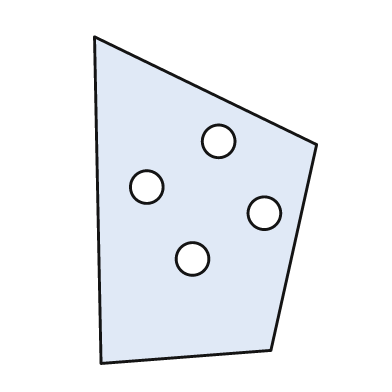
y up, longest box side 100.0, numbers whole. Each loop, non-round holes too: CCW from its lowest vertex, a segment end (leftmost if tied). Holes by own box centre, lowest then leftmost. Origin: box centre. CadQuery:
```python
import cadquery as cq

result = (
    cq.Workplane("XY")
    .moveTo(-32.0, -50.0)
    .lineTo(20.0, -46.0)
    .lineTo(34.0, 17.0)
    .lineTo(-34.0, 50.0)
    .close()
    .moveTo(-4.0, -18.0)
    .circle(5.0)
    .moveTo(18.0, -4.0)
    .circle(5.0)
    .moveTo(-18.0, 4.0)
    .circle(5.0)
    .moveTo(4.0, 18.0)
    .circle(5.0)
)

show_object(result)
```